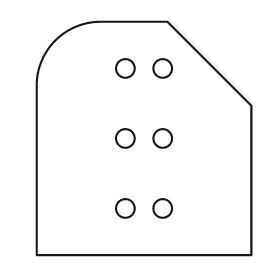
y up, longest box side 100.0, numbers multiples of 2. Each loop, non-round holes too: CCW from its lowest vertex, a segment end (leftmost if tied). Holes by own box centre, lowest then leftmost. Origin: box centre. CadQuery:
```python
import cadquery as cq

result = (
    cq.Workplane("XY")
    .moveTo(-46.0, -50.0)
    .lineTo(46.0, -50.0)
    .lineTo(46.0, 14.0)
    .lineTo(10.0, 50.0)
    .lineTo(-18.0, 50.0)
    .threePointArc((-38.0, 42.0), (-46.0, 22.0))
    .close()
    .moveTo(-8.0, -30.0)
    .circle(4.0)
    .moveTo(8.0, -30.0)
    .circle(4.0)
    .moveTo(-8.0, 0.0)
    .circle(4.0)
    .moveTo(8.0, 0.0)
    .circle(4.0)
    .moveTo(-8.0, 30.0)
    .circle(4.0)
    .moveTo(8.0, 30.0)
    .circle(4.0)
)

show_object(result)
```